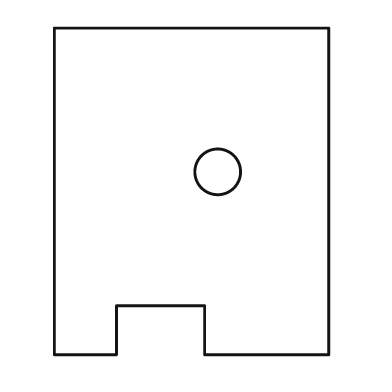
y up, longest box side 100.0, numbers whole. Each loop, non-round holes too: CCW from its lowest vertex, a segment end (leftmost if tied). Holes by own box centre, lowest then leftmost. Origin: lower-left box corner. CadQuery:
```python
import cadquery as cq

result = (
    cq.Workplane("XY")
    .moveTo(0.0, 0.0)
    .lineTo(19.0, 0.0)
    .lineTo(19.0, 15.0)
    .lineTo(46.0, 15.0)
    .lineTo(46.0, 0.0)
    .lineTo(84.0, 0.0)
    .lineTo(84.0, 100.0)
    .lineTo(0.0, 100.0)
    .close()
    .moveTo(50.0, 56.0)
    .circle(7.0)
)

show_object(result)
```